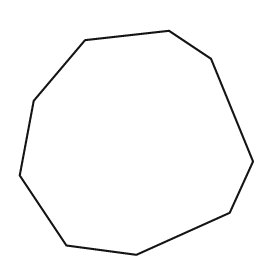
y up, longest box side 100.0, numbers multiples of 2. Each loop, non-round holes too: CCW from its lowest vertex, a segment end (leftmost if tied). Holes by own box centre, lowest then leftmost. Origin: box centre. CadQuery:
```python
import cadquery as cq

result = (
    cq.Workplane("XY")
    .moveTo(0.0, -48.0)
    .lineTo(40.0, -30.0)
    .lineTo(50.0, -8.0)
    .lineTo(32.0, 36.0)
    .lineTo(14.0, 48.0)
    .lineTo(-22.0, 44.0)
    .lineTo(-44.0, 18.0)
    .lineTo(-50.0, -14.0)
    .lineTo(-30.0, -44.0)
    .close()
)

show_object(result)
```